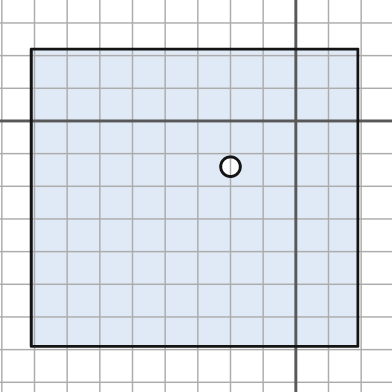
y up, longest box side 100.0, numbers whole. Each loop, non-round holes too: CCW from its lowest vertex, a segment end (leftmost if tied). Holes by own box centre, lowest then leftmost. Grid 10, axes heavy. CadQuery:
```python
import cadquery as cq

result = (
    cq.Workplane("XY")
    .moveTo(-81.0, -69.0)
    .lineTo(19.0, -69.0)
    .lineTo(19.0, 22.0)
    .lineTo(-81.0, 22.0)
    .close()
    .moveTo(-20.0, -14.0)
    .circle(3.0)
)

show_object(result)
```